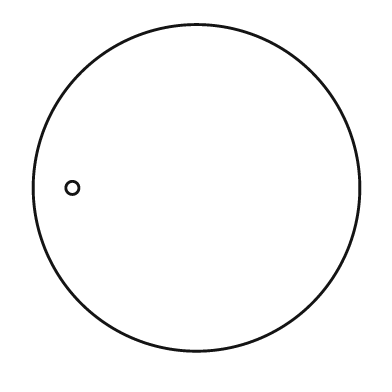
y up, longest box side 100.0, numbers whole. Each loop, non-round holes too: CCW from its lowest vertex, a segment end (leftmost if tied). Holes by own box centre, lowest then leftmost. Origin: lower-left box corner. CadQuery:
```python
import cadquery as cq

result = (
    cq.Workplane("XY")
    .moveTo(50.0, 50.0)
    .circle(50.0)
    .moveTo(12.0, 50.0)
    .circle(2.0)
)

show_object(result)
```